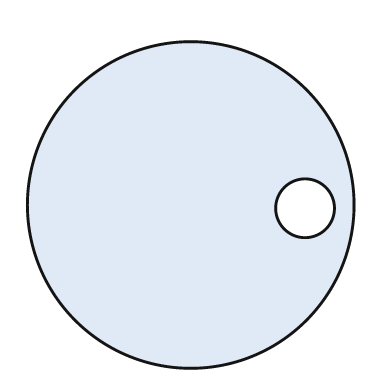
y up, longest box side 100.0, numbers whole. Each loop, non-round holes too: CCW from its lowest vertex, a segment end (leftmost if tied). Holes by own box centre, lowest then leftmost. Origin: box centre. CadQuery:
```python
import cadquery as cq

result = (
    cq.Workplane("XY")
    .moveTo(0.0, 0.0)
    .circle(50.0)
    .moveTo(35.0, -1.0)
    .circle(9.0)
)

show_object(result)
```